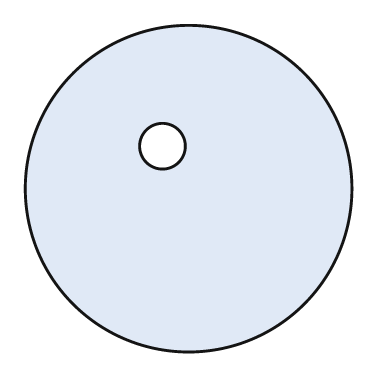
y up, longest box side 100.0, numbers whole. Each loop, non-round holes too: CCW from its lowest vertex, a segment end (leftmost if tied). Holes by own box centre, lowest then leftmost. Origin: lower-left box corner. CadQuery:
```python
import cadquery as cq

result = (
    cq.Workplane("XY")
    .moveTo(50.0, 50.0)
    .circle(50.0)
    .moveTo(42.0, 63.0)
    .circle(7.0)
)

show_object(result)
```